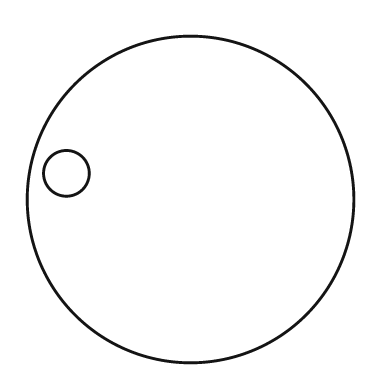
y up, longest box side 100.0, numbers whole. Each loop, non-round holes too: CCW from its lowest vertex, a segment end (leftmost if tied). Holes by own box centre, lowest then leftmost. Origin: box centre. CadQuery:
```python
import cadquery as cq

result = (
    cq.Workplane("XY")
    .moveTo(0.0, 0.0)
    .circle(50.0)
    .moveTo(-38.0, 8.0)
    .circle(7.0)
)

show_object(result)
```